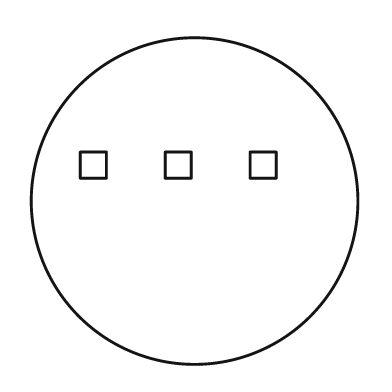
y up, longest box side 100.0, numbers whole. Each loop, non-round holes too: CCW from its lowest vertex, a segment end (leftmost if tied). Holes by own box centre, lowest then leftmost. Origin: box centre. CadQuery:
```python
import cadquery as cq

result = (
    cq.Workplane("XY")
    .moveTo(0.0, 0.0)
    .circle(50.0)
    .moveTo(-35.0, 7.0)
    .lineTo(-27.0, 7.0)
    .lineTo(-27.0, 15.0)
    .lineTo(-35.0, 15.0)
    .close()
    .moveTo(-9.0, 7.0)
    .lineTo(-1.0, 7.0)
    .lineTo(-1.0, 15.0)
    .lineTo(-9.0, 15.0)
    .close()
    .moveTo(17.0, 7.0)
    .lineTo(25.0, 7.0)
    .lineTo(25.0, 15.0)
    .lineTo(17.0, 15.0)
    .close()
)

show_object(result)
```